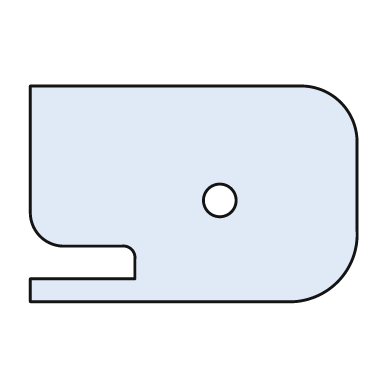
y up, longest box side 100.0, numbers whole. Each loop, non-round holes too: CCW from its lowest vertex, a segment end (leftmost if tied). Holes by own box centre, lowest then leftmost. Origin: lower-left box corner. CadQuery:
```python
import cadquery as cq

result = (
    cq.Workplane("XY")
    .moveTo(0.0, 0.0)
    .lineTo(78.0, 0.0)
    .threePointArc((94.0, 6.0), (100.0, 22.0))
    .lineTo(100.0, 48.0)
    .threePointArc((95.0, 61.0), (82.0, 66.0))
    .lineTo(0.0, 66.0)
    .lineTo(0.0, 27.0)
    .threePointArc((3.0, 20.0), (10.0, 17.0))
    .lineTo(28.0, 17.0)
    .threePointArc((31.0, 16.0), (32.0, 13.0))
    .lineTo(32.0, 7.0)
    .lineTo(0.0, 7.0)
    .close()
    .moveTo(58.0, 31.0)
    .circle(5.0)
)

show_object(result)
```